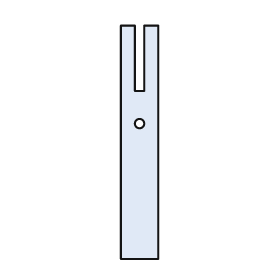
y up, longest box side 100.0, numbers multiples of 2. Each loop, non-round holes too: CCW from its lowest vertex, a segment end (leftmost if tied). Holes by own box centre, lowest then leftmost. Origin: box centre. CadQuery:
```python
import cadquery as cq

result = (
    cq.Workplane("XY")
    .moveTo(-8.0, -50.0)
    .lineTo(8.0, -50.0)
    .lineTo(8.0, 50.0)
    .lineTo(2.0, 50.0)
    .lineTo(2.0, 22.0)
    .lineTo(-2.0, 22.0)
    .lineTo(-2.0, 50.0)
    .lineTo(-8.0, 50.0)
    .close()
    .moveTo(0.0, 8.0)
    .circle(2.0)
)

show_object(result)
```